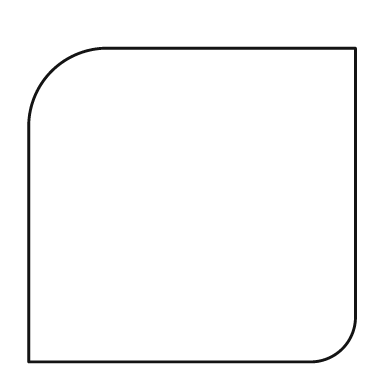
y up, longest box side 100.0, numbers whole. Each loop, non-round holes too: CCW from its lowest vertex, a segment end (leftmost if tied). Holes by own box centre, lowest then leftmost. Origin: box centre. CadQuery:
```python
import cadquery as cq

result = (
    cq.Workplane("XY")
    .moveTo(-50.0, -48.0)
    .lineTo(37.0, -48.0)
    .threePointArc((46.0, -44.0), (50.0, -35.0))
    .lineTo(50.0, 48.0)
    .lineTo(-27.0, 48.0)
    .threePointArc((-43.0, 41.0), (-50.0, 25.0))
    .close()
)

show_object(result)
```